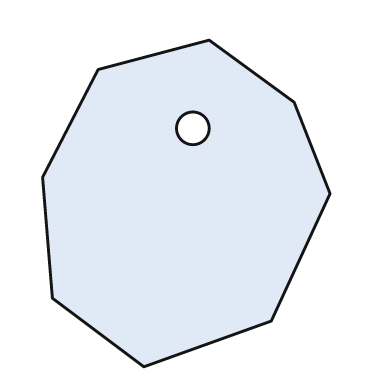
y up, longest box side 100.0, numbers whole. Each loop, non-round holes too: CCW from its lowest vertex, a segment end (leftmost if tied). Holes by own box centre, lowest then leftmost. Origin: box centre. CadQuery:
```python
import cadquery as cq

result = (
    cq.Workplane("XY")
    .moveTo(-13.0, -50.0)
    .lineTo(26.0, -36.0)
    .lineTo(44.0, 3.0)
    .lineTo(33.0, 31.0)
    .lineTo(7.0, 50.0)
    .lineTo(-27.0, 41.0)
    .lineTo(-44.0, 8.0)
    .lineTo(-41.0, -29.0)
    .close()
    .moveTo(2.0, 23.0)
    .circle(5.0)
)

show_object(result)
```